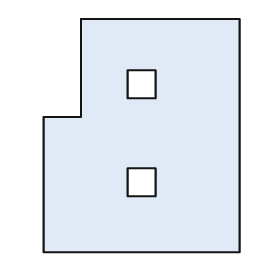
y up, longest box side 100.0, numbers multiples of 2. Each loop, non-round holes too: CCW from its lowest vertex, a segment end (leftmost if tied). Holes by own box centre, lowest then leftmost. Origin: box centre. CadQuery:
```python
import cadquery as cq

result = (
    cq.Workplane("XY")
    .moveTo(-42.0, -50.0)
    .lineTo(42.0, -50.0)
    .lineTo(42.0, 50.0)
    .lineTo(-26.0, 50.0)
    .lineTo(-26.0, 8.0)
    .lineTo(-42.0, 8.0)
    .close()
    .moveTo(-6.0, -26.0)
    .lineTo(6.0, -26.0)
    .lineTo(6.0, -14.0)
    .lineTo(-6.0, -14.0)
    .close()
    .moveTo(-6.0, 16.0)
    .lineTo(6.0, 16.0)
    .lineTo(6.0, 28.0)
    .lineTo(-6.0, 28.0)
    .close()
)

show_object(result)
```